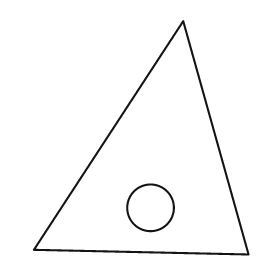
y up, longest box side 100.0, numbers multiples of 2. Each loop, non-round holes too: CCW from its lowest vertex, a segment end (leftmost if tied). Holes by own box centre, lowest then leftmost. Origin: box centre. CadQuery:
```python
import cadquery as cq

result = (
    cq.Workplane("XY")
    .moveTo(46.0, -50.0)
    .lineTo(18.0, 50.0)
    .lineTo(-46.0, -48.0)
    .close()
    .moveTo(4.0, -30.0)
    .circle(10.0)
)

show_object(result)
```